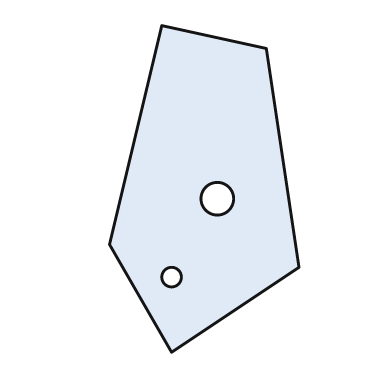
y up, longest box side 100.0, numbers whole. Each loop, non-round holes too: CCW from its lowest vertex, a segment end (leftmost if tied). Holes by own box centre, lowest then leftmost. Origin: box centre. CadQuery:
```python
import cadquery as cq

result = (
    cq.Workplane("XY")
    .moveTo(-10.0, -50.0)
    .lineTo(29.0, -24.0)
    .lineTo(19.0, 43.0)
    .lineTo(-13.0, 50.0)
    .lineTo(-29.0, -17.0)
    .close()
    .moveTo(-10.0, -27.0)
    .circle(3.0)
    .moveTo(4.0, -3.0)
    .circle(5.0)
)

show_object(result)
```